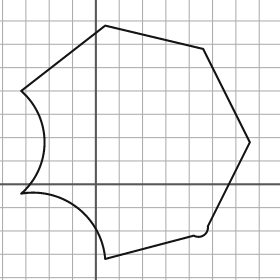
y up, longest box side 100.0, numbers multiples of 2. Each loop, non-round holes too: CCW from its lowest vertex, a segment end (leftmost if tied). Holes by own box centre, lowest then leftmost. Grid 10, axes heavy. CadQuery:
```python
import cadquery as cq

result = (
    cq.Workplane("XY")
    .moveTo(4.0, -32.0)
    .lineTo(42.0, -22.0)
    .threePointArc((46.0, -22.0), (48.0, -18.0))
    .lineTo(66.0, 18.0)
    .lineTo(46.0, 58.0)
    .lineTo(4.0, 68.0)
    .lineTo(-32.0, 40.0)
    .threePointArc((-22.0, 18.0), (-32.0, -4.0))
    .threePointArc((-8.0, -10.0), (4.0, -32.0))
    .close()
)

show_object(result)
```